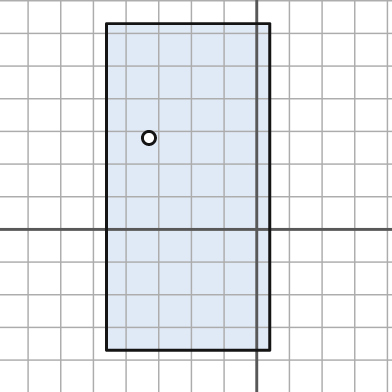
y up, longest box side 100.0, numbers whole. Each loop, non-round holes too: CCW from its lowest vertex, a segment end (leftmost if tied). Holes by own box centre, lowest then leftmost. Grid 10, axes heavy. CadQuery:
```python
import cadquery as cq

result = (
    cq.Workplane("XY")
    .moveTo(-46.0, -37.0)
    .lineTo(4.0, -37.0)
    .lineTo(4.0, 63.0)
    .lineTo(-46.0, 63.0)
    .close()
    .moveTo(-33.0, 28.0)
    .circle(2.0)
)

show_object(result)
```